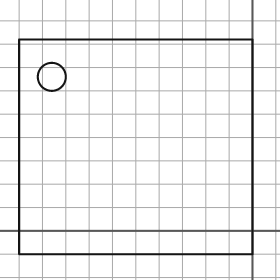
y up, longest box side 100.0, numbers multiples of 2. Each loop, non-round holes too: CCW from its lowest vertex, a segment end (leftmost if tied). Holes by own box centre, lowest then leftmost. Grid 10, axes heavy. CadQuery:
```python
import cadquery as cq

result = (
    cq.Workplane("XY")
    .moveTo(-100.0, -10.0)
    .lineTo(0.0, -10.0)
    .lineTo(0.0, 82.0)
    .lineTo(-100.0, 82.0)
    .close()
    .moveTo(-86.0, 66.0)
    .circle(6.0)
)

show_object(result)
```